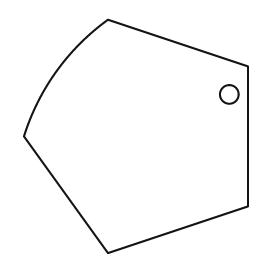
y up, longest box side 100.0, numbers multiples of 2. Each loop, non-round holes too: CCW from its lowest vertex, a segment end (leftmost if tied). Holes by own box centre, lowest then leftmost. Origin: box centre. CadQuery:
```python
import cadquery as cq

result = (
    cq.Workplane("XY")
    .moveTo(-12.0, -50.0)
    .lineTo(48.0, -30.0)
    .lineTo(48.0, 30.0)
    .lineTo(-12.0, 50.0)
    .threePointArc((-34.0, 28.0), (-48.0, 0.0))
    .close()
    .moveTo(40.0, 18.0)
    .circle(4.0)
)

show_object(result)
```